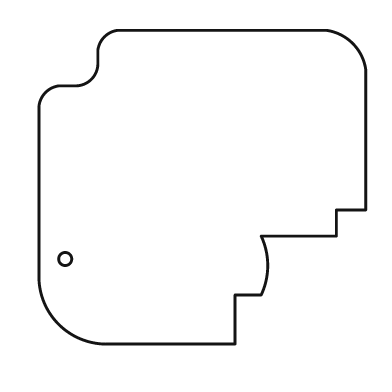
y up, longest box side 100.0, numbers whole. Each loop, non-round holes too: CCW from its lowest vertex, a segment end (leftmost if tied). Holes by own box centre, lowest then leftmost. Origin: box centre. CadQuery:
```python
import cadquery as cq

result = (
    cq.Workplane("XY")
    .moveTo(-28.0, -48.0)
    .lineTo(10.0, -48.0)
    .lineTo(10.0, -33.0)
    .lineTo(18.0, -33.0)
    .threePointArc((20.0, -24.0), (18.0, -15.0))
    .lineTo(41.0, -15.0)
    .lineTo(41.0, -7.0)
    .lineTo(50.0, -7.0)
    .lineTo(50.0, 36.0)
    .threePointArc((46.0, 44.0), (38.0, 48.0))
    .lineTo(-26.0, 48.0)
    .threePointArc((-30.0, 46.0), (-32.0, 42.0))
    .lineTo(-32.0, 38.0)
    .threePointArc((-34.0, 33.0), (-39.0, 31.0))
    .lineTo(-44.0, 31.0)
    .threePointArc((-48.0, 29.0), (-50.0, 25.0))
    .lineTo(-50.0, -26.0)
    .threePointArc((-44.0, -42.0), (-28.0, -48.0))
    .close()
    .moveTo(-42.0, -22.0)
    .circle(2.0)
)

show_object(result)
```